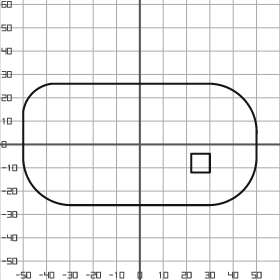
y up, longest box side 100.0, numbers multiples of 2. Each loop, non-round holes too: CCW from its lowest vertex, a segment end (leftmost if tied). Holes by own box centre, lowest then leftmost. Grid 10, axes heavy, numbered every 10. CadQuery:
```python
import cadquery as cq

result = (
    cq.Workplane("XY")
    .moveTo(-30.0, -26.0)
    .lineTo(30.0, -26.0)
    .threePointArc((44.0, -20.0), (50.0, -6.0))
    .lineTo(50.0, 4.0)
    .threePointArc((44.0, 20.0), (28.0, 26.0))
    .lineTo(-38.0, 26.0)
    .threePointArc((-46.0, 22.0), (-50.0, 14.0))
    .lineTo(-50.0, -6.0)
    .threePointArc((-44.0, -20.0), (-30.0, -26.0))
    .close()
    .moveTo(22.0, -12.0)
    .lineTo(30.0, -12.0)
    .lineTo(30.0, -4.0)
    .lineTo(22.0, -4.0)
    .close()
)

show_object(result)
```